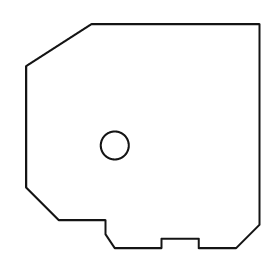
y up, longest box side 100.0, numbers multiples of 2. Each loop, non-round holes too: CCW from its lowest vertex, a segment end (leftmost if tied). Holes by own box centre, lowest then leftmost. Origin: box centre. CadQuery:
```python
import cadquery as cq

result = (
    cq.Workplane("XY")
    .moveTo(-12.0, -48.0)
    .lineTo(8.0, -48.0)
    .lineTo(8.0, -44.0)
    .lineTo(24.0, -44.0)
    .lineTo(24.0, -48.0)
    .lineTo(40.0, -48.0)
    .lineTo(50.0, -38.0)
    .lineTo(50.0, 48.0)
    .lineTo(-22.0, 48.0)
    .lineTo(-50.0, 30.0)
    .lineTo(-50.0, -22.0)
    .lineTo(-36.0, -36.0)
    .lineTo(-16.0, -36.0)
    .lineTo(-16.0, -42.0)
    .close()
    .moveTo(-12.0, -4.0)
    .circle(6.0)
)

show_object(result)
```